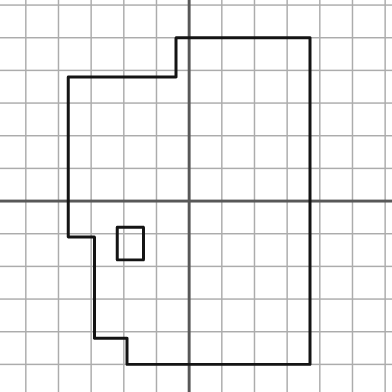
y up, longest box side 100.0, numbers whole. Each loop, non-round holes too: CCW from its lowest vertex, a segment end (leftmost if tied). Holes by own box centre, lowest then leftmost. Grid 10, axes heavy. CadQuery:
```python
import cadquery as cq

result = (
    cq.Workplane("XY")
    .moveTo(-19.0, -50.0)
    .lineTo(37.0, -50.0)
    .lineTo(37.0, 50.0)
    .lineTo(-4.0, 50.0)
    .lineTo(-4.0, 38.0)
    .lineTo(-37.0, 38.0)
    .lineTo(-37.0, -11.0)
    .lineTo(-29.0, -11.0)
    .lineTo(-29.0, -42.0)
    .lineTo(-19.0, -42.0)
    .close()
    .moveTo(-22.0, -18.0)
    .lineTo(-14.0, -18.0)
    .lineTo(-14.0, -8.0)
    .lineTo(-22.0, -8.0)
    .close()
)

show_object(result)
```